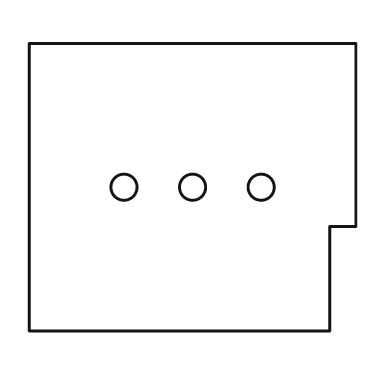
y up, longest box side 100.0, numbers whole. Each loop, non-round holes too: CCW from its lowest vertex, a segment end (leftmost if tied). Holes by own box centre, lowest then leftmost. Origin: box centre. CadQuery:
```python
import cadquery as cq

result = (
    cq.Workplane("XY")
    .moveTo(-50.0, -44.0)
    .lineTo(42.0, -44.0)
    .lineTo(42.0, -12.0)
    .lineTo(50.0, -12.0)
    .lineTo(50.0, 44.0)
    .lineTo(-50.0, 44.0)
    .close()
    .moveTo(-21.0, 0.0)
    .circle(4.0)
    .moveTo(0.0, 0.0)
    .circle(4.0)
    .moveTo(21.0, 0.0)
    .circle(4.0)
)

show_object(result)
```